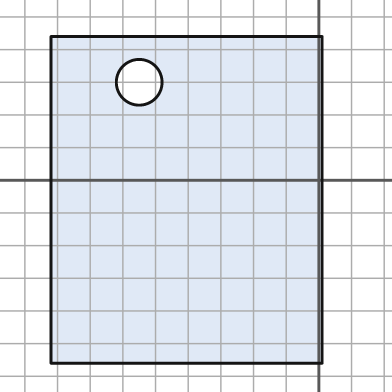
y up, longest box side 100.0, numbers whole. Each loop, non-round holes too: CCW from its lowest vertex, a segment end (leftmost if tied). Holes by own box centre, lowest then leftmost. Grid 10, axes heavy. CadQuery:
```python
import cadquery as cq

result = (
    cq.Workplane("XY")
    .moveTo(-82.0, -56.0)
    .lineTo(1.0, -56.0)
    .lineTo(1.0, 44.0)
    .lineTo(-82.0, 44.0)
    .close()
    .moveTo(-55.0, 30.0)
    .circle(7.0)
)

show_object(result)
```